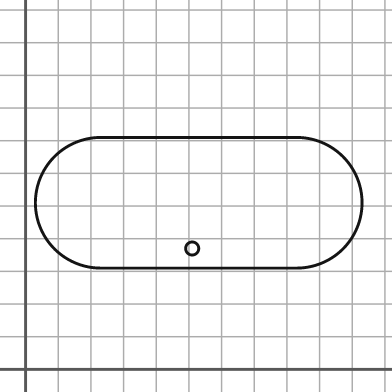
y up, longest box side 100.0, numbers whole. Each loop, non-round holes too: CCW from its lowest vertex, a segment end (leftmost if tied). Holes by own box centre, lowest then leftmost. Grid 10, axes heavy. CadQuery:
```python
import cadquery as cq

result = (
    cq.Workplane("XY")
    .moveTo(23.0, 31.0)
    .lineTo(83.0, 31.0)
    .threePointArc((103.0, 51.0), (83.0, 71.0))
    .lineTo(23.0, 71.0)
    .threePointArc((3.0, 51.0), (23.0, 31.0))
    .close()
    .moveTo(51.0, 37.0)
    .circle(2.0)
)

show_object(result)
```